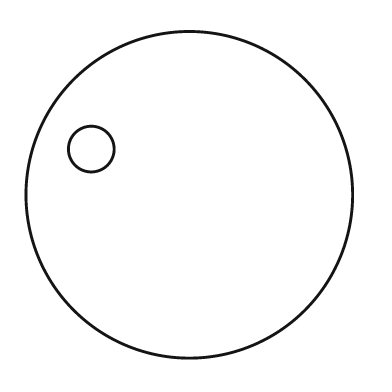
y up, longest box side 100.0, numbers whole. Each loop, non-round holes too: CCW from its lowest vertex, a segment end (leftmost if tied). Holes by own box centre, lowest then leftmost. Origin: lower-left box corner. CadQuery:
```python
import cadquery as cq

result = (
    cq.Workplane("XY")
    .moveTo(50.0, 50.0)
    .circle(50.0)
    .moveTo(20.0, 64.0)
    .circle(7.0)
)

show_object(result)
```